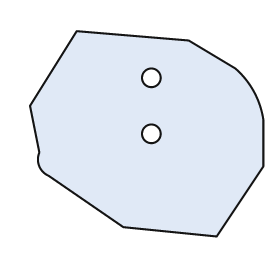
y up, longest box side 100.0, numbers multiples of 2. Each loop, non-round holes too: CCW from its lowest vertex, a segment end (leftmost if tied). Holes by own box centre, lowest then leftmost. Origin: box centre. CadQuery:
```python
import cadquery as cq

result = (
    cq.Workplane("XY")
    .moveTo(30.0, -44.0)
    .lineTo(50.0, -14.0)
    .lineTo(50.0, 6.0)
    .threePointArc((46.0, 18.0), (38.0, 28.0))
    .lineTo(18.0, 40.0)
    .lineTo(-30.0, 44.0)
    .lineTo(-50.0, 12.0)
    .lineTo(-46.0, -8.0)
    .threePointArc((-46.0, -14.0), (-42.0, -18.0))
    .lineTo(-10.0, -40.0)
    .close()
    .moveTo(2.0, 0.0)
    .circle(4.0)
    .moveTo(2.0, 24.0)
    .circle(4.0)
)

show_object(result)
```